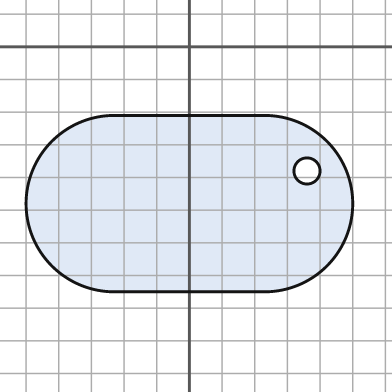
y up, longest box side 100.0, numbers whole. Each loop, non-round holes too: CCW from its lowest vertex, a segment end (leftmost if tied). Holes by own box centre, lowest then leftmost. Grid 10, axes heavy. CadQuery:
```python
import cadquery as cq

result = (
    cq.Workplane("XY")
    .moveTo(-23.0, -75.0)
    .lineTo(23.0, -75.0)
    .threePointArc((50.0, -48.0), (23.0, -21.0))
    .lineTo(-23.0, -21.0)
    .threePointArc((-50.0, -48.0), (-23.0, -75.0))
    .close()
    .moveTo(36.0, -38.0)
    .circle(4.0)
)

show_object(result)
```